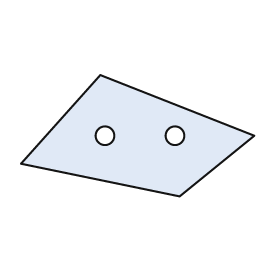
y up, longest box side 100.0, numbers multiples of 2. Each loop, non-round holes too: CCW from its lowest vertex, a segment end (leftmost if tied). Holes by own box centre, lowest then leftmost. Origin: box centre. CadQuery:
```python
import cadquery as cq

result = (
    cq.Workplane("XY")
    .moveTo(18.0, -26.0)
    .lineTo(50.0, 0.0)
    .lineTo(-16.0, 26.0)
    .lineTo(-50.0, -12.0)
    .close()
    .moveTo(-14.0, 0.0)
    .circle(4.0)
    .moveTo(16.0, 0.0)
    .circle(4.0)
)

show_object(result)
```